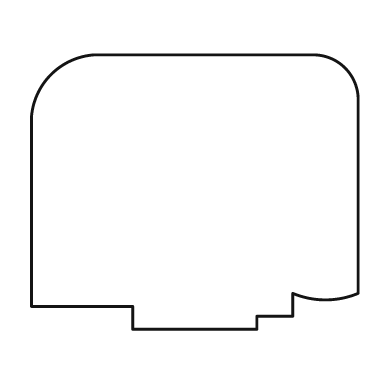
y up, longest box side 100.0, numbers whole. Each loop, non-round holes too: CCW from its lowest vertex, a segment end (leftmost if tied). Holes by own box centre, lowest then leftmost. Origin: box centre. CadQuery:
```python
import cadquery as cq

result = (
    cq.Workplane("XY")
    .moveTo(-19.0, -42.0)
    .lineTo(19.0, -42.0)
    .lineTo(19.0, -38.0)
    .lineTo(30.0, -38.0)
    .lineTo(30.0, -31.0)
    .threePointArc((40.0, -33.0), (50.0, -31.0))
    .lineTo(50.0, 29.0)
    .threePointArc((46.0, 38.0), (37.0, 42.0))
    .lineTo(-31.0, 42.0)
    .threePointArc((-44.0, 36.0), (-50.0, 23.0))
    .lineTo(-50.0, -35.0)
    .lineTo(-19.0, -35.0)
    .close()
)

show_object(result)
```